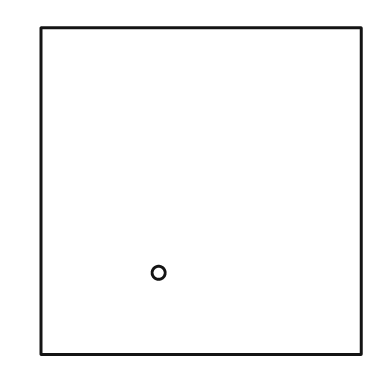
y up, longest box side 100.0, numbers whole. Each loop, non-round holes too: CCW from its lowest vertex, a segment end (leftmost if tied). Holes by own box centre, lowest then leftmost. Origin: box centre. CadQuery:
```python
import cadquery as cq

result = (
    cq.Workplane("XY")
    .moveTo(-49.0, -50.0)
    .lineTo(49.0, -50.0)
    .lineTo(49.0, 50.0)
    .lineTo(-49.0, 50.0)
    .close()
    .moveTo(-13.0, -25.0)
    .circle(2.0)
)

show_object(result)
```